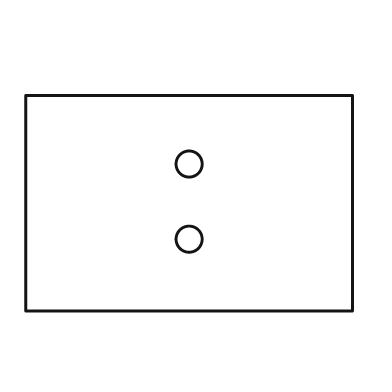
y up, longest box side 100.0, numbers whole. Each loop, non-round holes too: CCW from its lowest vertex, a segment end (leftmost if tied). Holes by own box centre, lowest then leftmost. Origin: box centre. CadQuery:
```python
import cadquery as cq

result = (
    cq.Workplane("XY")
    .moveTo(-50.0, -33.0)
    .lineTo(50.0, -33.0)
    .lineTo(50.0, 33.0)
    .lineTo(-50.0, 33.0)
    .close()
    .moveTo(0.0, -11.0)
    .circle(4.0)
    .moveTo(0.0, 12.0)
    .circle(4.0)
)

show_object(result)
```